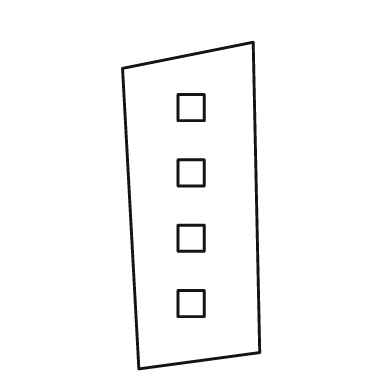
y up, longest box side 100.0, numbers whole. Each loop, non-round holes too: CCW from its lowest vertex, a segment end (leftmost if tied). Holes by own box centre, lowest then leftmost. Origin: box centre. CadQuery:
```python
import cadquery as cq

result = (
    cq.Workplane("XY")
    .moveTo(-16.0, -50.0)
    .lineTo(21.0, -45.0)
    .lineTo(19.0, 50.0)
    .lineTo(-21.0, 42.0)
    .close()
    .moveTo(-4.0, -34.0)
    .lineTo(4.0, -34.0)
    .lineTo(4.0, -26.0)
    .lineTo(-4.0, -26.0)
    .close()
    .moveTo(-4.0, -14.0)
    .lineTo(4.0, -14.0)
    .lineTo(4.0, -6.0)
    .lineTo(-4.0, -6.0)
    .close()
    .moveTo(-4.0, 6.0)
    .lineTo(4.0, 6.0)
    .lineTo(4.0, 14.0)
    .lineTo(-4.0, 14.0)
    .close()
    .moveTo(-4.0, 26.0)
    .lineTo(4.0, 26.0)
    .lineTo(4.0, 34.0)
    .lineTo(-4.0, 34.0)
    .close()
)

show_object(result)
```